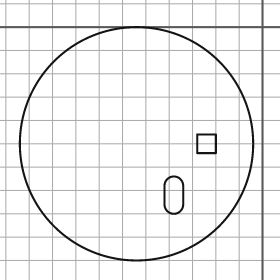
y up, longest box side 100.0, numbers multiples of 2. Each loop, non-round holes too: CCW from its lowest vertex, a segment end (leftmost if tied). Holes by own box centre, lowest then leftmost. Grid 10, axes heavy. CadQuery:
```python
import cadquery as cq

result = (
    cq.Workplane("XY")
    .moveTo(-54.0, -50.0)
    .circle(50.0)
    .moveTo(-42.0, -76.0)
    .threePointArc((-38.0, -80.0), (-34.0, -76.0))
    .lineTo(-34.0, -68.0)
    .threePointArc((-38.0, -64.0), (-42.0, -68.0))
    .close()
    .moveTo(-28.0, -54.0)
    .lineTo(-20.0, -54.0)
    .lineTo(-20.0, -46.0)
    .lineTo(-28.0, -46.0)
    .close()
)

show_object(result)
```